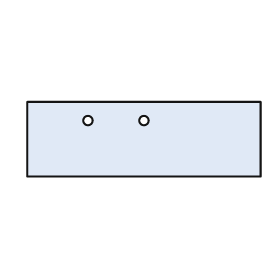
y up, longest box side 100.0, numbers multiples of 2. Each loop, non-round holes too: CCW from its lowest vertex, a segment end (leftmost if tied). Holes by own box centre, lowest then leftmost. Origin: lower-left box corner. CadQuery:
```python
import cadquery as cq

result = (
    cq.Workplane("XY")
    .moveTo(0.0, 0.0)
    .lineTo(100.0, 0.0)
    .lineTo(100.0, 32.0)
    .lineTo(0.0, 32.0)
    .close()
    .moveTo(26.0, 24.0)
    .circle(2.0)
    .moveTo(50.0, 24.0)
    .circle(2.0)
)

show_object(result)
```